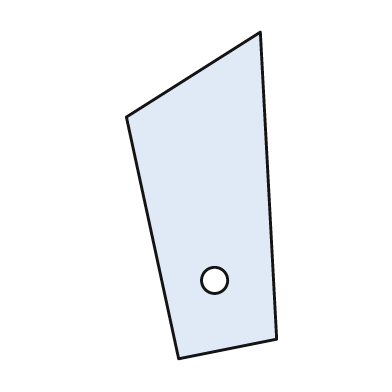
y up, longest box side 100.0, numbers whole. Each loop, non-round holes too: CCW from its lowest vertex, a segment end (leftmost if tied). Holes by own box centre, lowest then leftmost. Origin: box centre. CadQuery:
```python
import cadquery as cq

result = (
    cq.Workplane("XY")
    .moveTo(-7.0, -50.0)
    .lineTo(23.0, -44.0)
    .lineTo(18.0, 50.0)
    .lineTo(-23.0, 24.0)
    .close()
    .moveTo(4.0, -26.0)
    .circle(4.0)
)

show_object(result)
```